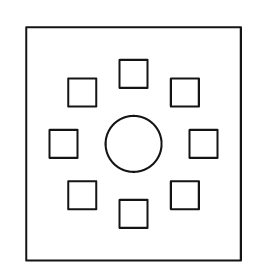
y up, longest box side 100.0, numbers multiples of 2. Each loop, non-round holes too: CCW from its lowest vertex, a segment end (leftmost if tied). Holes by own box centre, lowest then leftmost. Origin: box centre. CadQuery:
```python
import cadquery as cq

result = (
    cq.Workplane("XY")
    .moveTo(-46.0, -50.0)
    .lineTo(46.0, -50.0)
    .lineTo(46.0, 50.0)
    .lineTo(-46.0, 50.0)
    .close()
    .moveTo(-6.0, -36.0)
    .lineTo(6.0, -36.0)
    .lineTo(6.0, -24.0)
    .lineTo(-6.0, -24.0)
    .close()
    .moveTo(-28.0, -28.0)
    .lineTo(-16.0, -28.0)
    .lineTo(-16.0, -16.0)
    .lineTo(-28.0, -16.0)
    .close()
    .moveTo(16.0, -28.0)
    .lineTo(28.0, -28.0)
    .lineTo(28.0, -16.0)
    .lineTo(16.0, -16.0)
    .close()
    .moveTo(-36.0, -6.0)
    .lineTo(-24.0, -6.0)
    .lineTo(-24.0, 6.0)
    .lineTo(-36.0, 6.0)
    .close()
    .moveTo(0.0, 0.0)
    .circle(12.0)
    .moveTo(24.0, -6.0)
    .lineTo(36.0, -6.0)
    .lineTo(36.0, 6.0)
    .lineTo(24.0, 6.0)
    .close()
    .moveTo(-28.0, 16.0)
    .lineTo(-16.0, 16.0)
    .lineTo(-16.0, 28.0)
    .lineTo(-28.0, 28.0)
    .close()
    .moveTo(16.0, 16.0)
    .lineTo(28.0, 16.0)
    .lineTo(28.0, 28.0)
    .lineTo(16.0, 28.0)
    .close()
    .moveTo(-6.0, 24.0)
    .lineTo(6.0, 24.0)
    .lineTo(6.0, 36.0)
    .lineTo(-6.0, 36.0)
    .close()
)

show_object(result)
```